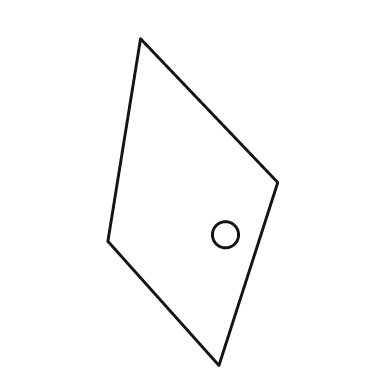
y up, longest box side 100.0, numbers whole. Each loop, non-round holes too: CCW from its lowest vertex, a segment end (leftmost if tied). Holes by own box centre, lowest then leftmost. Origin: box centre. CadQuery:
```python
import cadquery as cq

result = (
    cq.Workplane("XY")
    .moveTo(8.0, -50.0)
    .lineTo(26.0, 6.0)
    .lineTo(-16.0, 50.0)
    .lineTo(-26.0, -12.0)
    .close()
    .moveTo(10.0, -10.0)
    .circle(4.0)
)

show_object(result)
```